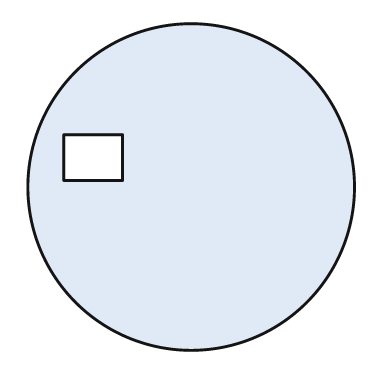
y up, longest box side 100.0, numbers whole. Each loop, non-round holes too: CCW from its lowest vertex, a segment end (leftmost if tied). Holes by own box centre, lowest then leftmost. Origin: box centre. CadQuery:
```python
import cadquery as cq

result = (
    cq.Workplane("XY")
    .moveTo(0.0, 0.0)
    .circle(50.0)
    .moveTo(-39.0, 2.0)
    .lineTo(-21.0, 2.0)
    .lineTo(-21.0, 16.0)
    .lineTo(-39.0, 16.0)
    .close()
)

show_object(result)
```